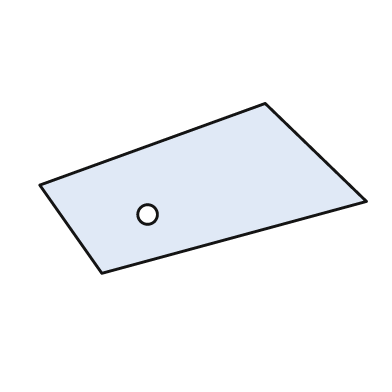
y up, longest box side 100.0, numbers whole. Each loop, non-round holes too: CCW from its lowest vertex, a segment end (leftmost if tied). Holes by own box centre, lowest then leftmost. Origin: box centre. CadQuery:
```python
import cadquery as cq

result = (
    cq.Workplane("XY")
    .moveTo(-31.0, -26.0)
    .lineTo(50.0, -4.0)
    .lineTo(19.0, 26.0)
    .lineTo(-50.0, 1.0)
    .close()
    .moveTo(-17.0, -8.0)
    .circle(3.0)
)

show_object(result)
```